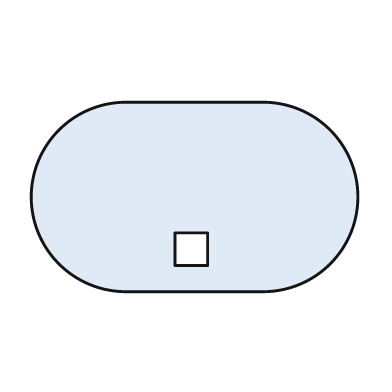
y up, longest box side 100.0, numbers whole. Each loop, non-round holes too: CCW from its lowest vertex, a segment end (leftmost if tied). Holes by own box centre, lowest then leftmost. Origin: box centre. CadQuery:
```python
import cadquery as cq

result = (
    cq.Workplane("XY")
    .moveTo(-21.0, -29.0)
    .lineTo(21.0, -29.0)
    .threePointArc((50.0, 0.0), (21.0, 29.0))
    .lineTo(-21.0, 29.0)
    .threePointArc((-50.0, 0.0), (-21.0, -29.0))
    .close()
    .moveTo(-6.0, -21.0)
    .lineTo(4.0, -21.0)
    .lineTo(4.0, -11.0)
    .lineTo(-6.0, -11.0)
    .close()
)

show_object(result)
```